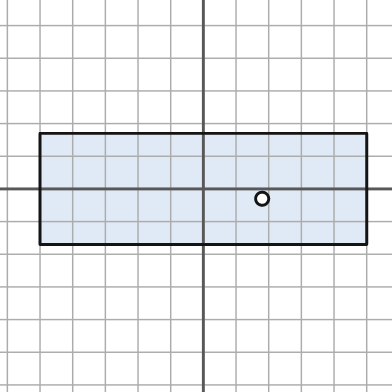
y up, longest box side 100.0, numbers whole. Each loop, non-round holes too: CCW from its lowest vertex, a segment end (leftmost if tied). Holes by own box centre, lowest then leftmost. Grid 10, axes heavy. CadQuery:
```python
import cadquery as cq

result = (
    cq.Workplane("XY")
    .moveTo(-50.0, -17.0)
    .lineTo(50.0, -17.0)
    .lineTo(50.0, 17.0)
    .lineTo(-50.0, 17.0)
    .close()
    .moveTo(18.0, -3.0)
    .circle(2.0)
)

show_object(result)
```